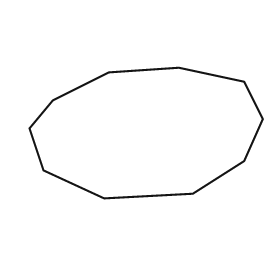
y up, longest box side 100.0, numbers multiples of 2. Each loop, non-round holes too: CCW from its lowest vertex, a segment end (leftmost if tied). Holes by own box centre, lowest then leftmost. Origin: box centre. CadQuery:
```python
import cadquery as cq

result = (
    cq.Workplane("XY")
    .moveTo(-18.0, -28.0)
    .lineTo(20.0, -26.0)
    .lineTo(42.0, -12.0)
    .lineTo(50.0, 6.0)
    .lineTo(42.0, 22.0)
    .lineTo(14.0, 28.0)
    .lineTo(-16.0, 26.0)
    .lineTo(-40.0, 14.0)
    .lineTo(-50.0, 2.0)
    .lineTo(-44.0, -16.0)
    .close()
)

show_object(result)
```